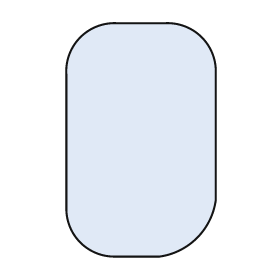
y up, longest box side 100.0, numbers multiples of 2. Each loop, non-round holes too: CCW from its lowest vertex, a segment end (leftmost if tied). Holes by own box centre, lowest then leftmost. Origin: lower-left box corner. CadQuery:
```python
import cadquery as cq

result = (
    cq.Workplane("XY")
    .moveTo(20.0, 0.0)
    .lineTo(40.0, 0.0)
    .threePointArc((56.0, 8.0), (64.0, 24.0))
    .lineTo(64.0, 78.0)
    .threePointArc((58.0, 94.0), (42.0, 100.0))
    .lineTo(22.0, 100.0)
    .threePointArc((6.0, 94.0), (0.0, 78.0))
    .lineTo(0.0, 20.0)
    .threePointArc((6.0, 6.0), (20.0, 0.0))
    .close()
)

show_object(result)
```